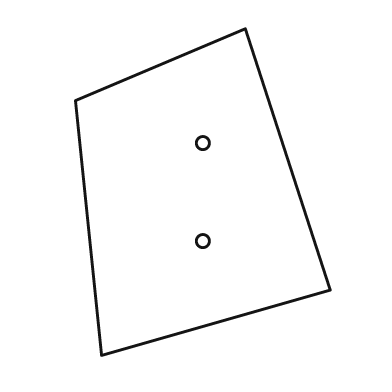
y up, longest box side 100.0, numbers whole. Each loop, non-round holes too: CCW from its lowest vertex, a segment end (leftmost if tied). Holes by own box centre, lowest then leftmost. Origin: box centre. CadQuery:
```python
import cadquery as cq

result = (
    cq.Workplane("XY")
    .moveTo(-31.0, -50.0)
    .lineTo(39.0, -30.0)
    .lineTo(13.0, 50.0)
    .lineTo(-39.0, 28.0)
    .close()
    .moveTo(0.0, -15.0)
    .circle(2.0)
    .moveTo(0.0, 15.0)
    .circle(2.0)
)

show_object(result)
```